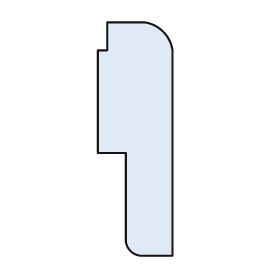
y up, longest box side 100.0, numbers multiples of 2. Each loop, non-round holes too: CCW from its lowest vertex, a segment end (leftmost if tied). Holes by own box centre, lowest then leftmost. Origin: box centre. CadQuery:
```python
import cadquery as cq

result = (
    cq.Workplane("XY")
    .moveTo(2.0, -50.0)
    .lineTo(16.0, -50.0)
    .lineTo(16.0, 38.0)
    .threePointArc((12.0, 46.0), (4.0, 50.0))
    .lineTo(-12.0, 50.0)
    .lineTo(-12.0, 38.0)
    .lineTo(-16.0, 38.0)
    .lineTo(-16.0, -6.0)
    .lineTo(-4.0, -6.0)
    .lineTo(-4.0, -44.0)
    .threePointArc((-2.0, -48.0), (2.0, -50.0))
    .close()
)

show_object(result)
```